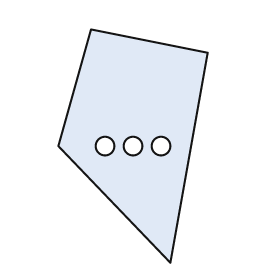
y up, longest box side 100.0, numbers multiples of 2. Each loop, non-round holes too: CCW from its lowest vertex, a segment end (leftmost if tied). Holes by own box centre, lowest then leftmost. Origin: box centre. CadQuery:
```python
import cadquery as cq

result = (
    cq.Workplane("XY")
    .moveTo(16.0, -50.0)
    .lineTo(32.0, 40.0)
    .lineTo(-18.0, 50.0)
    .lineTo(-32.0, 0.0)
    .close()
    .moveTo(-12.0, 0.0)
    .circle(4.0)
    .moveTo(0.0, 0.0)
    .circle(4.0)
    .moveTo(12.0, 0.0)
    .circle(4.0)
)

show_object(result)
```